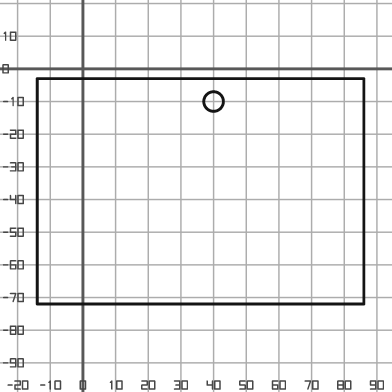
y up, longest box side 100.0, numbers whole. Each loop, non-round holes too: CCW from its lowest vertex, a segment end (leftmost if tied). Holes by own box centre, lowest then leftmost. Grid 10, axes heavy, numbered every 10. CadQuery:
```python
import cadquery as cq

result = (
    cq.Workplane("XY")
    .moveTo(-14.0, -72.0)
    .lineTo(86.0, -72.0)
    .lineTo(86.0, -3.0)
    .lineTo(-14.0, -3.0)
    .close()
    .moveTo(40.0, -10.0)
    .circle(3.0)
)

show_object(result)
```